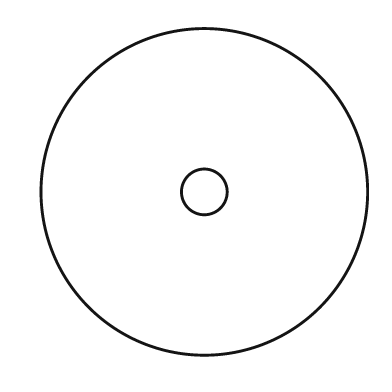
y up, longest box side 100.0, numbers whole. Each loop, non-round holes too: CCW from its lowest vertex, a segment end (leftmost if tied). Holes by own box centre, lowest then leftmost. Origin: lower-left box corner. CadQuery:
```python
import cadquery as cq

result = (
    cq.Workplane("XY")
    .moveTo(50.0, 50.0)
    .circle(50.0)
    .moveTo(50.0, 50.0)
    .circle(7.0)
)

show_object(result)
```